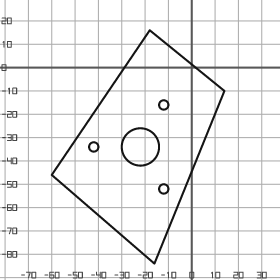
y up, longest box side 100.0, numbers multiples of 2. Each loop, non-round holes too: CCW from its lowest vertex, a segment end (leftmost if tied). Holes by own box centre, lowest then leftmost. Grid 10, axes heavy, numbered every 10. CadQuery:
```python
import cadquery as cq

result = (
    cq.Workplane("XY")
    .moveTo(-16.0, -84.0)
    .lineTo(14.0, -10.0)
    .lineTo(-18.0, 16.0)
    .lineTo(-60.0, -46.0)
    .close()
    .moveTo(-12.0, -52.0)
    .circle(2.0)
    .moveTo(-42.0, -34.0)
    .circle(2.0)
    .moveTo(-22.0, -34.0)
    .circle(8.0)
    .moveTo(-12.0, -16.0)
    .circle(2.0)
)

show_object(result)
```